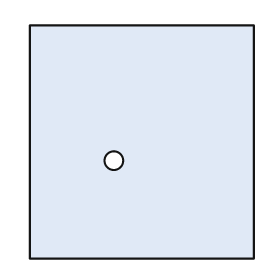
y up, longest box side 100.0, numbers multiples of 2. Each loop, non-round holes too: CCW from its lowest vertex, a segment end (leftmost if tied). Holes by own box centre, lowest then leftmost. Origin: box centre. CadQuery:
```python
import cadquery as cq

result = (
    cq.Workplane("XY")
    .moveTo(-48.0, -50.0)
    .lineTo(48.0, -50.0)
    .lineTo(48.0, 50.0)
    .lineTo(-48.0, 50.0)
    .close()
    .moveTo(-12.0, -8.0)
    .circle(4.0)
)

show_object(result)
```